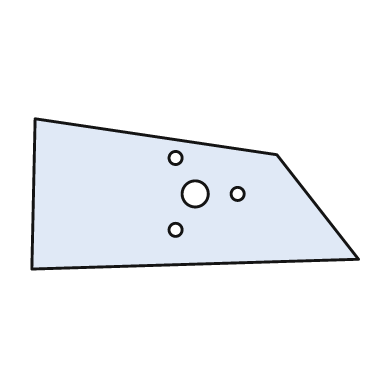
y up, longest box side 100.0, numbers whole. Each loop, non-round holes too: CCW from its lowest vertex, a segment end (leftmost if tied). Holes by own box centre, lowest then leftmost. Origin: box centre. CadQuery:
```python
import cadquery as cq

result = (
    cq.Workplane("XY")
    .moveTo(-50.0, -23.0)
    .lineTo(50.0, -20.0)
    .lineTo(25.0, 12.0)
    .lineTo(-49.0, 23.0)
    .close()
    .moveTo(-6.0, -11.0)
    .circle(2.0)
    .moveTo(0.0, 0.0)
    .circle(4.0)
    .moveTo(13.0, 0.0)
    .circle(2.0)
    .moveTo(-6.0, 11.0)
    .circle(2.0)
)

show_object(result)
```